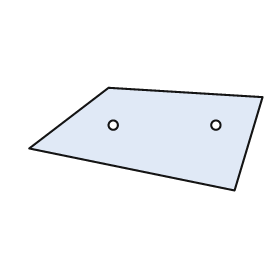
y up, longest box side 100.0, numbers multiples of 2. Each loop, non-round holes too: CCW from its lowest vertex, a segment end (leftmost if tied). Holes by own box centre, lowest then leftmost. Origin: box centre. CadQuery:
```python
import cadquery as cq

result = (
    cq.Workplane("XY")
    .moveTo(38.0, -22.0)
    .lineTo(50.0, 18.0)
    .lineTo(-16.0, 22.0)
    .lineTo(-50.0, -4.0)
    .close()
    .moveTo(-14.0, 6.0)
    .circle(2.0)
    .moveTo(30.0, 6.0)
    .circle(2.0)
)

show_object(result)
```